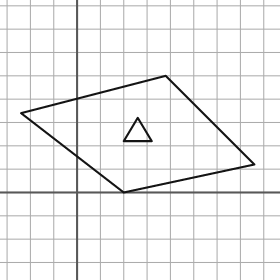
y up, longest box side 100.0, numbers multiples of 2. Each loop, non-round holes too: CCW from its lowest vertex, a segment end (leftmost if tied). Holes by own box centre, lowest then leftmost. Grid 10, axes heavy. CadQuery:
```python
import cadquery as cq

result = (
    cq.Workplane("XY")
    .moveTo(20.0, 0.0)
    .lineTo(76.0, 12.0)
    .lineTo(38.0, 50.0)
    .lineTo(-24.0, 34.0)
    .close()
    .moveTo(20.0, 22.0)
    .lineTo(32.0, 22.0)
    .lineTo(26.0, 32.0)
    .close()
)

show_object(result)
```